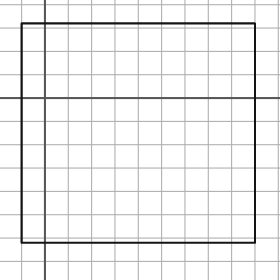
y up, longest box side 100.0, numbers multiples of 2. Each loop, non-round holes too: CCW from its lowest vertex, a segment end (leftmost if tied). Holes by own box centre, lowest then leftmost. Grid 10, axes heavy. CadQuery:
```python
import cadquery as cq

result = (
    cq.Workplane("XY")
    .moveTo(-10.0, -62.0)
    .lineTo(90.0, -62.0)
    .lineTo(90.0, 32.0)
    .lineTo(-10.0, 32.0)
    .close()
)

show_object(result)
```